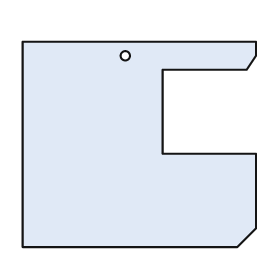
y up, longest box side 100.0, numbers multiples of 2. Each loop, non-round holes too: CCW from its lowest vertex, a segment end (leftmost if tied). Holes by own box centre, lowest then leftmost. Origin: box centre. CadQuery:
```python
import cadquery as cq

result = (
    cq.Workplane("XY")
    .moveTo(-50.0, -44.0)
    .lineTo(42.0, -44.0)
    .lineTo(50.0, -36.0)
    .lineTo(50.0, -4.0)
    .lineTo(10.0, -4.0)
    .lineTo(10.0, 32.0)
    .lineTo(46.0, 32.0)
    .lineTo(50.0, 38.0)
    .lineTo(50.0, 44.0)
    .lineTo(-50.0, 44.0)
    .close()
    .moveTo(-6.0, 38.0)
    .circle(2.0)
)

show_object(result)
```